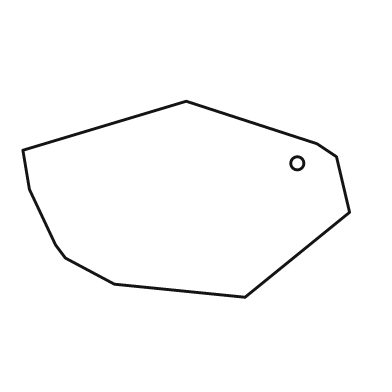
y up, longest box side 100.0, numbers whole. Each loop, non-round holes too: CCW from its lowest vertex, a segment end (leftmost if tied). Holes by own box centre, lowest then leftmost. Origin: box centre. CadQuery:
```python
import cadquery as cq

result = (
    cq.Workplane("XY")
    .moveTo(18.0, -30.0)
    .lineTo(50.0, -4.0)
    .lineTo(46.0, 13.0)
    .lineTo(40.0, 17.0)
    .lineTo(0.0, 30.0)
    .lineTo(-50.0, 15.0)
    .lineTo(-48.0, 3.0)
    .lineTo(-40.0, -14.0)
    .lineTo(-37.0, -18.0)
    .lineTo(-22.0, -26.0)
    .close()
    .moveTo(34.0, 11.0)
    .circle(2.0)
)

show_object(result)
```